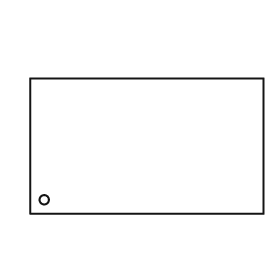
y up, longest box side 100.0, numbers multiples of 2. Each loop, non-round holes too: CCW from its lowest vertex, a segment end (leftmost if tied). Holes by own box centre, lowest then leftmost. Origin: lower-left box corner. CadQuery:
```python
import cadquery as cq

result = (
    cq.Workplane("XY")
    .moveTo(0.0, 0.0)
    .lineTo(100.0, 0.0)
    .lineTo(100.0, 58.0)
    .lineTo(0.0, 58.0)
    .close()
    .moveTo(6.0, 6.0)
    .circle(2.0)
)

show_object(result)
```